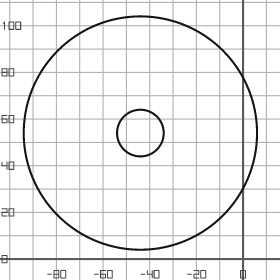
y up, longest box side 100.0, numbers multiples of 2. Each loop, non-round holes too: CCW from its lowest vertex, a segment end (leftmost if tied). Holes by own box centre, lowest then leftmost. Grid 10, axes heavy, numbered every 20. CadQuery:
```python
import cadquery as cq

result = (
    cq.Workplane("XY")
    .moveTo(-44.0, 54.0)
    .circle(50.0)
    .moveTo(-44.0, 54.0)
    .circle(10.0)
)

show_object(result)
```